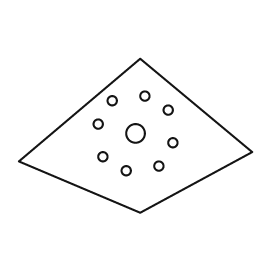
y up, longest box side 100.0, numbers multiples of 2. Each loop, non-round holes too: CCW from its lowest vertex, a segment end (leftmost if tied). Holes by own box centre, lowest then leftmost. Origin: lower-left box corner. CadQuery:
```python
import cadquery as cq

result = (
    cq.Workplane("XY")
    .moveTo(52.0, 0.0)
    .lineTo(100.0, 26.0)
    .lineTo(52.0, 66.0)
    .lineTo(0.0, 22.0)
    .close()
    .moveTo(46.0, 18.0)
    .circle(2.0)
    .moveTo(60.0, 20.0)
    .circle(2.0)
    .moveTo(36.0, 24.0)
    .circle(2.0)
    .moveTo(66.0, 30.0)
    .circle(2.0)
    .moveTo(50.0, 34.0)
    .circle(4.0)
    .moveTo(34.0, 38.0)
    .circle(2.0)
    .moveTo(64.0, 44.0)
    .circle(2.0)
    .moveTo(40.0, 48.0)
    .circle(2.0)
    .moveTo(54.0, 50.0)
    .circle(2.0)
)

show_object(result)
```